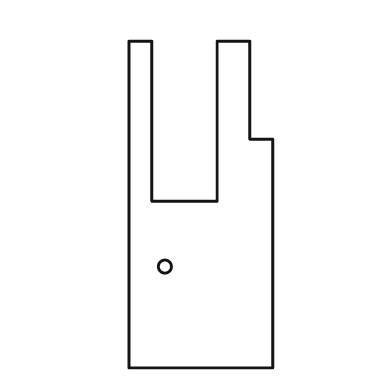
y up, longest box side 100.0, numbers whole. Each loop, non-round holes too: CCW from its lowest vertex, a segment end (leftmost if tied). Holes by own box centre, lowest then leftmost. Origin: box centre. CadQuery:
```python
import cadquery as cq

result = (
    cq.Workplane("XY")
    .moveTo(-22.0, -50.0)
    .lineTo(22.0, -50.0)
    .lineTo(22.0, 20.0)
    .lineTo(15.0, 20.0)
    .lineTo(15.0, 50.0)
    .lineTo(5.0, 50.0)
    .lineTo(5.0, 1.0)
    .lineTo(-15.0, 1.0)
    .lineTo(-15.0, 50.0)
    .lineTo(-22.0, 50.0)
    .close()
    .moveTo(-11.0, -19.0)
    .circle(2.0)
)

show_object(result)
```